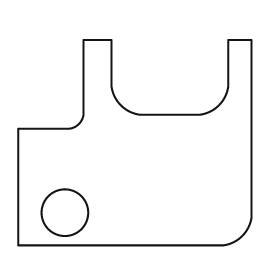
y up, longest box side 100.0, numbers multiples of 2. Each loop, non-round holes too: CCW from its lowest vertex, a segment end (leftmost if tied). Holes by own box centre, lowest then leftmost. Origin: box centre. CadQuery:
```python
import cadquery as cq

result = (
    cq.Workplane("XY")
    .moveTo(-50.0, -44.0)
    .lineTo(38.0, -44.0)
    .threePointArc((46.0, -40.0), (50.0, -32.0))
    .lineTo(50.0, 44.0)
    .lineTo(40.0, 44.0)
    .lineTo(40.0, 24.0)
    .threePointArc((36.0, 16.0), (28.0, 12.0))
    .lineTo(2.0, 12.0)
    .threePointArc((-6.0, 16.0), (-10.0, 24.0))
    .lineTo(-10.0, 44.0)
    .lineTo(-22.0, 44.0)
    .lineTo(-22.0, 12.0)
    .threePointArc((-24.0, 8.0), (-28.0, 6.0))
    .lineTo(-50.0, 6.0)
    .close()
    .moveTo(-30.0, -30.0)
    .circle(10.0)
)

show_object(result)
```